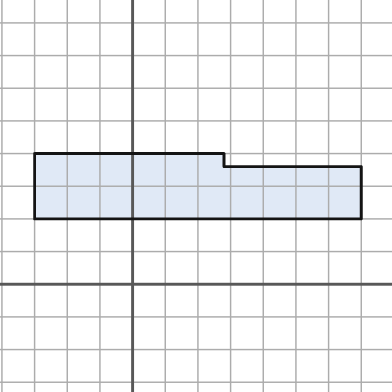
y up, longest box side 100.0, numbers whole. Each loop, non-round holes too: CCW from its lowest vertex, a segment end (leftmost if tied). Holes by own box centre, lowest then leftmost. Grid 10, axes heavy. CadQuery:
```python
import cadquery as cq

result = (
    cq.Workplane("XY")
    .moveTo(-30.0, 20.0)
    .lineTo(70.0, 20.0)
    .lineTo(70.0, 36.0)
    .lineTo(28.0, 36.0)
    .lineTo(28.0, 40.0)
    .lineTo(-30.0, 40.0)
    .close()
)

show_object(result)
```